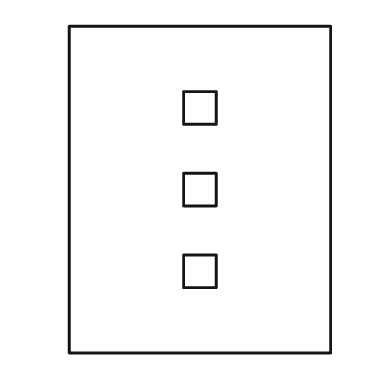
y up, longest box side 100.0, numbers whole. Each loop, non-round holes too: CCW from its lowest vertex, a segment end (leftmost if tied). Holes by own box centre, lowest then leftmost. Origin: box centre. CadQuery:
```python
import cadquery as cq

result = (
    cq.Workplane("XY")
    .moveTo(-40.0, -50.0)
    .lineTo(40.0, -50.0)
    .lineTo(40.0, 50.0)
    .lineTo(-40.0, 50.0)
    .close()
    .moveTo(-5.0, -30.0)
    .lineTo(5.0, -30.0)
    .lineTo(5.0, -20.0)
    .lineTo(-5.0, -20.0)
    .close()
    .moveTo(-5.0, -5.0)
    .lineTo(5.0, -5.0)
    .lineTo(5.0, 5.0)
    .lineTo(-5.0, 5.0)
    .close()
    .moveTo(-5.0, 20.0)
    .lineTo(5.0, 20.0)
    .lineTo(5.0, 30.0)
    .lineTo(-5.0, 30.0)
    .close()
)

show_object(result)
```